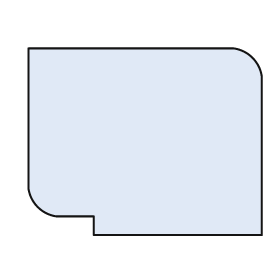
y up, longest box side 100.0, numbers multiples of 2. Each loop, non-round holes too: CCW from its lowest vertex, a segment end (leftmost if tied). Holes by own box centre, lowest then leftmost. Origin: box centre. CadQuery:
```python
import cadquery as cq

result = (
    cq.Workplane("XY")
    .moveTo(-22.0, -40.0)
    .lineTo(50.0, -40.0)
    .lineTo(50.0, 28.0)
    .threePointArc((46.0, 36.0), (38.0, 40.0))
    .lineTo(-50.0, 40.0)
    .lineTo(-50.0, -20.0)
    .threePointArc((-46.0, -28.0), (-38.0, -32.0))
    .lineTo(-22.0, -32.0)
    .close()
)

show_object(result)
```